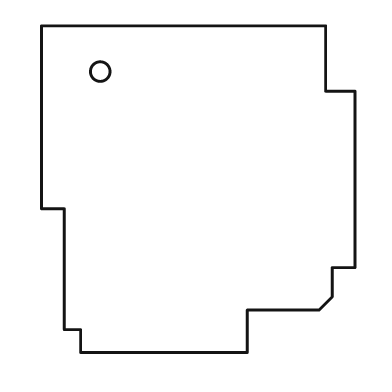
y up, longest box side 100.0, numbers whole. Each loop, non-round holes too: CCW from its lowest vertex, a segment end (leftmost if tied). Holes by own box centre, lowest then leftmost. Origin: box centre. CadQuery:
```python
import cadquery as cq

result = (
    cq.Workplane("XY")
    .moveTo(-36.0, -50.0)
    .lineTo(15.0, -50.0)
    .lineTo(15.0, -37.0)
    .lineTo(37.0, -37.0)
    .lineTo(41.0, -33.0)
    .lineTo(41.0, -24.0)
    .lineTo(48.0, -24.0)
    .lineTo(48.0, 30.0)
    .lineTo(39.0, 30.0)
    .lineTo(39.0, 50.0)
    .lineTo(-48.0, 50.0)
    .lineTo(-48.0, -6.0)
    .lineTo(-41.0, -6.0)
    .lineTo(-41.0, -43.0)
    .lineTo(-36.0, -43.0)
    .close()
    .moveTo(-30.0, 36.0)
    .circle(3.0)
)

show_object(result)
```